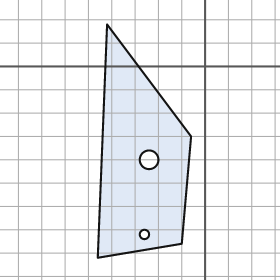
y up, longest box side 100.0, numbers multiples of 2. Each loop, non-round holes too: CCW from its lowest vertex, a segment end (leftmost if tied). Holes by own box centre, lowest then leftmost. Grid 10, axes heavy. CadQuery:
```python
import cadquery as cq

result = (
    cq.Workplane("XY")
    .moveTo(-46.0, -82.0)
    .lineTo(-10.0, -76.0)
    .lineTo(-6.0, -30.0)
    .lineTo(-42.0, 18.0)
    .close()
    .moveTo(-26.0, -72.0)
    .circle(2.0)
    .moveTo(-24.0, -40.0)
    .circle(4.0)
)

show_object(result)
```